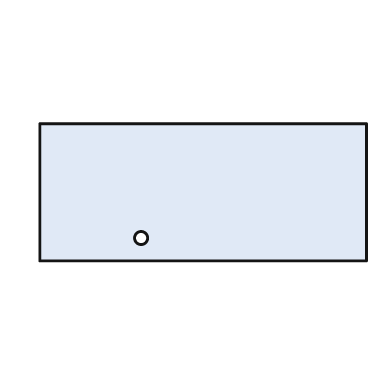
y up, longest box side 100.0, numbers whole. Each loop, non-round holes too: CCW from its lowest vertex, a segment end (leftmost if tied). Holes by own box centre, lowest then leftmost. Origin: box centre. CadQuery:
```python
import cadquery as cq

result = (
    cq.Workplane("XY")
    .moveTo(-50.0, -21.0)
    .lineTo(50.0, -21.0)
    .lineTo(50.0, 21.0)
    .lineTo(-50.0, 21.0)
    .close()
    .moveTo(-19.0, -14.0)
    .circle(2.0)
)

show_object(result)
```